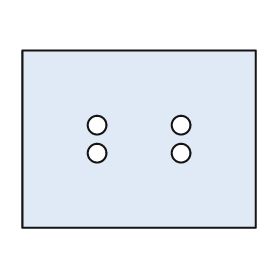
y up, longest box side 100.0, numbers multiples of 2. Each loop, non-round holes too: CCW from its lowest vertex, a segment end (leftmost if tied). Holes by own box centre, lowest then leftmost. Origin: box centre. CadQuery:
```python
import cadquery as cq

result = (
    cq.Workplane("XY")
    .moveTo(-50.0, -38.0)
    .lineTo(50.0, -38.0)
    .lineTo(50.0, 38.0)
    .lineTo(-50.0, 38.0)
    .close()
    .moveTo(-18.0, -6.0)
    .circle(4.0)
    .moveTo(18.0, -6.0)
    .circle(4.0)
    .moveTo(-18.0, 6.0)
    .circle(4.0)
    .moveTo(18.0, 6.0)
    .circle(4.0)
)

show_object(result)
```